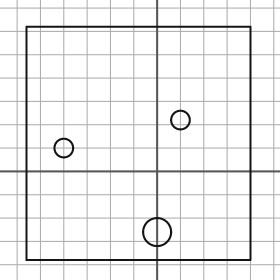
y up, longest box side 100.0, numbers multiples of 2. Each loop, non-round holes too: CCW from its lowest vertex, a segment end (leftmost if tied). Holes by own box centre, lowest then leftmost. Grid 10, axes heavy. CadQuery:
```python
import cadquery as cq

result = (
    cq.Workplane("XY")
    .moveTo(-56.0, -38.0)
    .lineTo(40.0, -38.0)
    .lineTo(40.0, 62.0)
    .lineTo(-56.0, 62.0)
    .close()
    .moveTo(0.0, -26.0)
    .circle(6.0)
    .moveTo(-40.0, 10.0)
    .circle(4.0)
    .moveTo(10.0, 22.0)
    .circle(4.0)
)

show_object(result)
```